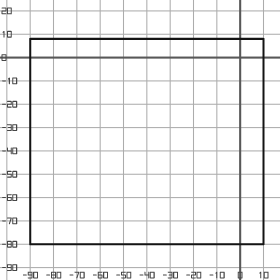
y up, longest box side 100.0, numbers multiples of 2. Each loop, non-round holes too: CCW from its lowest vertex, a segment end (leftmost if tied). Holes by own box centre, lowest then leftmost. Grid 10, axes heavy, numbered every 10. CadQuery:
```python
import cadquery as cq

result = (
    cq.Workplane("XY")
    .moveTo(-90.0, -80.0)
    .lineTo(10.0, -80.0)
    .lineTo(10.0, 8.0)
    .lineTo(-90.0, 8.0)
    .close()
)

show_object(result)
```